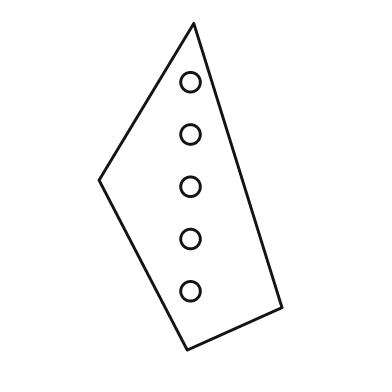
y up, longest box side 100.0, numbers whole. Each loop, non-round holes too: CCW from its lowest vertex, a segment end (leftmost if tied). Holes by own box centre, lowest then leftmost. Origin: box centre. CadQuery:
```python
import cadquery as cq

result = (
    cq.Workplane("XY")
    .moveTo(-1.0, -50.0)
    .lineTo(28.0, -37.0)
    .lineTo(1.0, 50.0)
    .lineTo(-28.0, 2.0)
    .close()
    .moveTo(0.0, -32.0)
    .circle(3.0)
    .moveTo(0.0, -16.0)
    .circle(3.0)
    .moveTo(0.0, 0.0)
    .circle(3.0)
    .moveTo(0.0, 16.0)
    .circle(3.0)
    .moveTo(0.0, 32.0)
    .circle(3.0)
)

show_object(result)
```